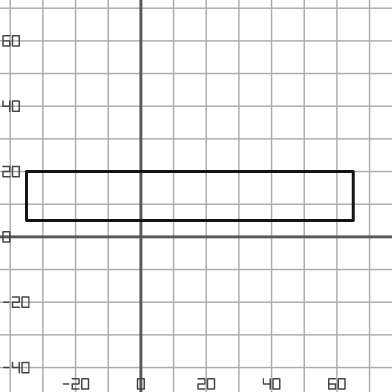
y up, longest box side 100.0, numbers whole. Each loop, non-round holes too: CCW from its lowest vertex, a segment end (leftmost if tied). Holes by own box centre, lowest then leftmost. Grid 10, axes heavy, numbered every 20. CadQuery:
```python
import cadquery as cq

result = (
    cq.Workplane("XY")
    .moveTo(-35.0, 5.0)
    .lineTo(65.0, 5.0)
    .lineTo(65.0, 20.0)
    .lineTo(-35.0, 20.0)
    .close()
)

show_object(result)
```